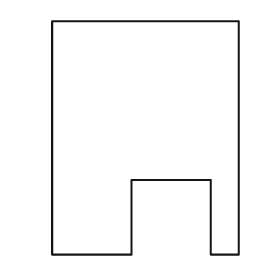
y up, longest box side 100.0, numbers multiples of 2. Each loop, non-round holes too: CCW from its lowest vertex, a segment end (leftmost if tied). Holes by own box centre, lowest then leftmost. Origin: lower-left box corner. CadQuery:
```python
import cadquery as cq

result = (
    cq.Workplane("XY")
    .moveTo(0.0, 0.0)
    .lineTo(34.0, 0.0)
    .lineTo(34.0, 32.0)
    .lineTo(68.0, 32.0)
    .lineTo(68.0, 0.0)
    .lineTo(80.0, 0.0)
    .lineTo(80.0, 100.0)
    .lineTo(0.0, 100.0)
    .close()
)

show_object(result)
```